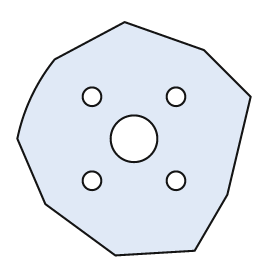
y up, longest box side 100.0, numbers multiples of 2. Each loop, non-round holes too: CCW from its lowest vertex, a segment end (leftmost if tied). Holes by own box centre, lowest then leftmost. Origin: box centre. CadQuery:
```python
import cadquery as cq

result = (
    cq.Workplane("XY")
    .moveTo(-8.0, -50.0)
    .lineTo(26.0, -48.0)
    .lineTo(40.0, -24.0)
    .lineTo(50.0, 18.0)
    .lineTo(30.0, 38.0)
    .lineTo(-4.0, 50.0)
    .lineTo(-34.0, 34.0)
    .threePointArc((-44.0, 18.0), (-50.0, 0.0))
    .lineTo(-38.0, -28.0)
    .close()
    .moveTo(-18.0, -18.0)
    .circle(4.0)
    .moveTo(18.0, -18.0)
    .circle(4.0)
    .moveTo(0.0, 0.0)
    .circle(10.0)
    .moveTo(-18.0, 18.0)
    .circle(4.0)
    .moveTo(18.0, 18.0)
    .circle(4.0)
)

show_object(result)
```